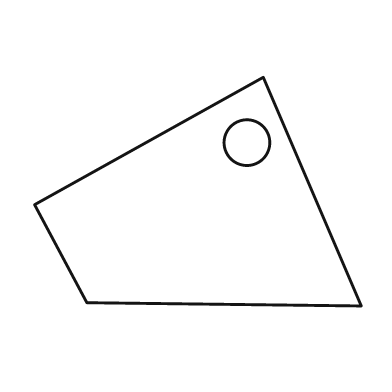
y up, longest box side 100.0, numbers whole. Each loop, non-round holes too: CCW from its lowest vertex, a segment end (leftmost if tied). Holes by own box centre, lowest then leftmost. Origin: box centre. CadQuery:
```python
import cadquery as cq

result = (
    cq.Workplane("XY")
    .moveTo(50.0, -35.0)
    .lineTo(20.0, 35.0)
    .lineTo(-50.0, -4.0)
    .lineTo(-34.0, -34.0)
    .close()
    .moveTo(15.0, 15.0)
    .circle(7.0)
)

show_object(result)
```